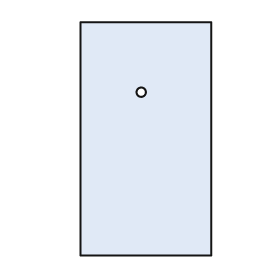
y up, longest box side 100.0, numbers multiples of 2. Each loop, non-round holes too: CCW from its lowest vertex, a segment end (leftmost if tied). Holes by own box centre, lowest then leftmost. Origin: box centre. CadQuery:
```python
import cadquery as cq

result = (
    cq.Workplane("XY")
    .moveTo(-28.0, -50.0)
    .lineTo(28.0, -50.0)
    .lineTo(28.0, 50.0)
    .lineTo(-28.0, 50.0)
    .close()
    .moveTo(-2.0, 20.0)
    .circle(2.0)
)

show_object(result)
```